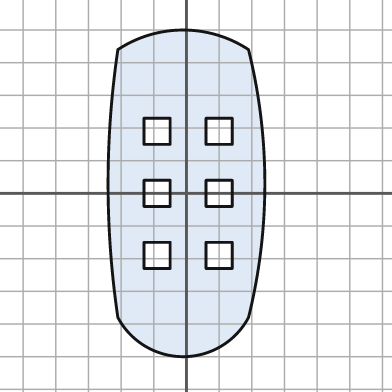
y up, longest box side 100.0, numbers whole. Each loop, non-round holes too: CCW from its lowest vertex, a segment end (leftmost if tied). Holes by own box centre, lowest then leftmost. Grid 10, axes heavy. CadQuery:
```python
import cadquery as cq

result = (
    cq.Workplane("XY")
    .moveTo(-21.0, -38.0)
    .threePointArc((-1.0, -50.0), (19.0, -38.0))
    .threePointArc((24.0, 3.0), (19.0, 44.0))
    .threePointArc((-1.0, 50.0), (-21.0, 44.0))
    .threePointArc((-24.0, 3.0), (-21.0, -38.0))
    .close()
    .moveTo(-13.0, -23.0)
    .lineTo(-5.0, -23.0)
    .lineTo(-5.0, -15.0)
    .lineTo(-13.0, -15.0)
    .close()
    .moveTo(6.0, -23.0)
    .lineTo(14.0, -23.0)
    .lineTo(14.0, -15.0)
    .lineTo(6.0, -15.0)
    .close()
    .moveTo(-13.0, -4.0)
    .lineTo(-5.0, -4.0)
    .lineTo(-5.0, 4.0)
    .lineTo(-13.0, 4.0)
    .close()
    .moveTo(6.0, -4.0)
    .lineTo(14.0, -4.0)
    .lineTo(14.0, 4.0)
    .lineTo(6.0, 4.0)
    .close()
    .moveTo(-13.0, 15.0)
    .lineTo(-5.0, 15.0)
    .lineTo(-5.0, 23.0)
    .lineTo(-13.0, 23.0)
    .close()
    .moveTo(6.0, 15.0)
    .lineTo(14.0, 15.0)
    .lineTo(14.0, 23.0)
    .lineTo(6.0, 23.0)
    .close()
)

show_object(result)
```